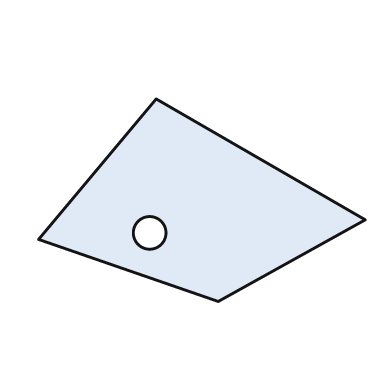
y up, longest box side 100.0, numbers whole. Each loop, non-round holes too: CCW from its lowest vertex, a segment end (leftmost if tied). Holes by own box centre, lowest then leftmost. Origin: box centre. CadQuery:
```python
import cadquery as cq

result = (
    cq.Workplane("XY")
    .moveTo(5.0, -31.0)
    .lineTo(50.0, -6.0)
    .lineTo(-14.0, 31.0)
    .lineTo(-50.0, -12.0)
    .close()
    .moveTo(-16.0, -10.0)
    .circle(5.0)
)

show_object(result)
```